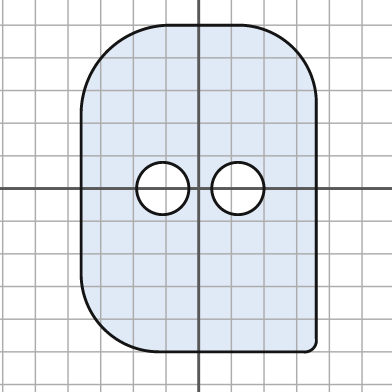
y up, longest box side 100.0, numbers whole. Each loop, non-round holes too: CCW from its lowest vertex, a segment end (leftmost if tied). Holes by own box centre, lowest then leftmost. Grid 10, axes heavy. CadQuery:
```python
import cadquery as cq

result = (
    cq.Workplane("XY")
    .moveTo(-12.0, -50.0)
    .lineTo(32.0, -50.0)
    .threePointArc((35.0, -49.0), (36.0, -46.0))
    .lineTo(36.0, 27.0)
    .threePointArc((29.0, 43.0), (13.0, 50.0))
    .lineTo(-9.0, 50.0)
    .threePointArc((-28.0, 42.0), (-36.0, 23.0))
    .lineTo(-36.0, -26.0)
    .threePointArc((-29.0, -43.0), (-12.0, -50.0))
    .close()
    .moveTo(-11.0, 0.0)
    .circle(8.0)
    .moveTo(12.0, 0.0)
    .circle(8.0)
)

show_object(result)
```